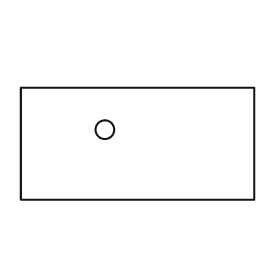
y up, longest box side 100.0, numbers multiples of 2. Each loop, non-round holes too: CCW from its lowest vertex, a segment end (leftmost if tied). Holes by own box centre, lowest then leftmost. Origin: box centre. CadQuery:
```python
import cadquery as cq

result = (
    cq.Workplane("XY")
    .moveTo(-50.0, -24.0)
    .lineTo(50.0, -24.0)
    .lineTo(50.0, 24.0)
    .lineTo(-50.0, 24.0)
    .close()
    .moveTo(-14.0, 6.0)
    .circle(4.0)
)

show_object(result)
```